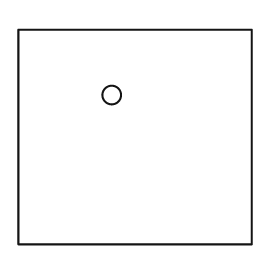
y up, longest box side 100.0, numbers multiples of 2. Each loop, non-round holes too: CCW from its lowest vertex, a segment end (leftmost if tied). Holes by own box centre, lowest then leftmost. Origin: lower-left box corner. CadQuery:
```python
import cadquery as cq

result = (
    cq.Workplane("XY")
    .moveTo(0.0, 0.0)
    .lineTo(100.0, 0.0)
    .lineTo(100.0, 92.0)
    .lineTo(0.0, 92.0)
    .close()
    .moveTo(40.0, 64.0)
    .circle(4.0)
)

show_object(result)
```